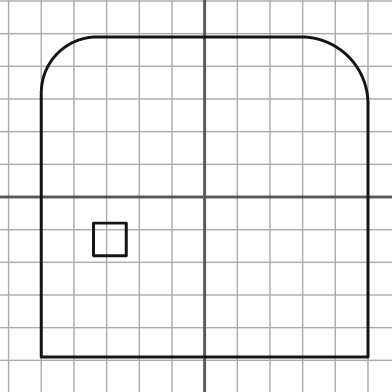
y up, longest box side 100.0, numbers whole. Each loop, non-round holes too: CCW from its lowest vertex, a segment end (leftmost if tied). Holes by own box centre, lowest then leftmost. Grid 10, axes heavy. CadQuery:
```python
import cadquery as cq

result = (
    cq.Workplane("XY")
    .moveTo(-50.0, -49.0)
    .lineTo(50.0, -49.0)
    .lineTo(50.0, 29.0)
    .threePointArc((44.0, 43.0), (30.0, 49.0))
    .lineTo(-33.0, 49.0)
    .threePointArc((-45.0, 44.0), (-50.0, 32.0))
    .close()
    .moveTo(-34.0, -18.0)
    .lineTo(-24.0, -18.0)
    .lineTo(-24.0, -8.0)
    .lineTo(-34.0, -8.0)
    .close()
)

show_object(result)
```